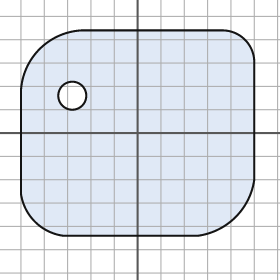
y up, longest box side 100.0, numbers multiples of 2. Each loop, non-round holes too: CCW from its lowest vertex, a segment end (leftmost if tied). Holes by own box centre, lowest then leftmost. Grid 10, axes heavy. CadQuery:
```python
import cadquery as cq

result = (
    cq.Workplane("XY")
    .moveTo(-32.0, -44.0)
    .lineTo(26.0, -44.0)
    .threePointArc((42.0, -36.0), (50.0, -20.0))
    .lineTo(50.0, 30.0)
    .threePointArc((46.0, 40.0), (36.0, 44.0))
    .lineTo(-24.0, 44.0)
    .threePointArc((-42.0, 36.0), (-50.0, 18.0))
    .lineTo(-50.0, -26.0)
    .threePointArc((-44.0, -38.0), (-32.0, -44.0))
    .close()
    .moveTo(-28.0, 16.0)
    .circle(6.0)
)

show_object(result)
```